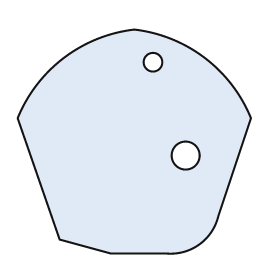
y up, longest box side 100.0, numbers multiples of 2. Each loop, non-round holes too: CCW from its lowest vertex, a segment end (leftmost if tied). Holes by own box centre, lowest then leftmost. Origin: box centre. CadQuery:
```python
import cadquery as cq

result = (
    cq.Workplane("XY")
    .moveTo(-10.0, -48.0)
    .lineTo(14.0, -48.0)
    .threePointArc((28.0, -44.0), (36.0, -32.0))
    .lineTo(50.0, 10.0)
    .threePointArc((30.0, 36.0), (0.0, 48.0))
    .threePointArc((-30.0, 36.0), (-50.0, 10.0))
    .lineTo(-32.0, -42.0)
    .close()
    .moveTo(22.0, -6.0)
    .circle(6.0)
    .moveTo(8.0, 34.0)
    .circle(4.0)
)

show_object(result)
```